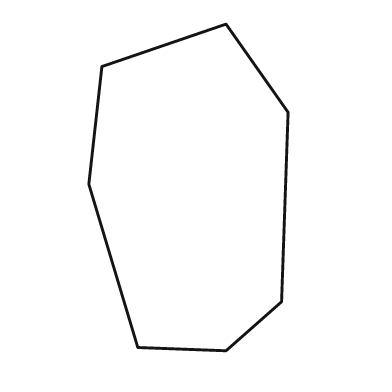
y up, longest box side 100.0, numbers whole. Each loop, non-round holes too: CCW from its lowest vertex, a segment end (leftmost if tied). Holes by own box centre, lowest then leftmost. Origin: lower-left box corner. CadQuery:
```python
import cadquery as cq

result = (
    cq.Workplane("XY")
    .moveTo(42.0, 0.0)
    .lineTo(59.0, 15.0)
    .lineTo(61.0, 73.0)
    .lineTo(42.0, 100.0)
    .lineTo(4.0, 87.0)
    .lineTo(0.0, 51.0)
    .lineTo(15.0, 1.0)
    .close()
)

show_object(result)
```